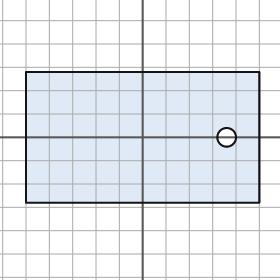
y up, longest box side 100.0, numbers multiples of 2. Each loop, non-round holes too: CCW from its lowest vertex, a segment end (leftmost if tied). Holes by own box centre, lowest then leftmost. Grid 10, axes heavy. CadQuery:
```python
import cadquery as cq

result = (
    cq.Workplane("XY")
    .moveTo(-50.0, -28.0)
    .lineTo(50.0, -28.0)
    .lineTo(50.0, 28.0)
    .lineTo(-50.0, 28.0)
    .close()
    .moveTo(36.0, 0.0)
    .circle(4.0)
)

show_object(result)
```